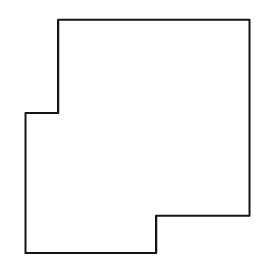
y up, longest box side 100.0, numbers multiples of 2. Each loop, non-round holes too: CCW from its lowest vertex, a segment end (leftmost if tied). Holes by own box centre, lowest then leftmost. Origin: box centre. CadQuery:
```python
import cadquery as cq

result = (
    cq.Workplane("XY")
    .moveTo(-48.0, -50.0)
    .lineTo(8.0, -50.0)
    .lineTo(8.0, -34.0)
    .lineTo(48.0, -34.0)
    .lineTo(48.0, 50.0)
    .lineTo(-34.0, 50.0)
    .lineTo(-34.0, 10.0)
    .lineTo(-48.0, 10.0)
    .close()
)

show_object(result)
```